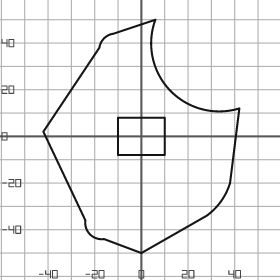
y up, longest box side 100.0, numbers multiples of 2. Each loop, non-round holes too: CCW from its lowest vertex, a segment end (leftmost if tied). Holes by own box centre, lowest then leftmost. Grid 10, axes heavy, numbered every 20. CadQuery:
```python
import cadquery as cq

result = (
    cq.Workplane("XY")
    .moveTo(0.0, -50.0)
    .lineTo(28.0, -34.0)
    .threePointArc((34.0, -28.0), (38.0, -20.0))
    .lineTo(42.0, 12.0)
    .threePointArc((12.0, 20.0), (6.0, 50.0))
    .lineTo(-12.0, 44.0)
    .threePointArc((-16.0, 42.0), (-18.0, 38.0))
    .lineTo(-42.0, 2.0)
    .lineTo(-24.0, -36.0)
    .threePointArc((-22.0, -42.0), (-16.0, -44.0))
    .close()
    .moveTo(-10.0, -8.0)
    .lineTo(10.0, -8.0)
    .lineTo(10.0, 8.0)
    .lineTo(-10.0, 8.0)
    .close()
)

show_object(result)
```